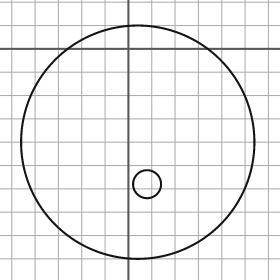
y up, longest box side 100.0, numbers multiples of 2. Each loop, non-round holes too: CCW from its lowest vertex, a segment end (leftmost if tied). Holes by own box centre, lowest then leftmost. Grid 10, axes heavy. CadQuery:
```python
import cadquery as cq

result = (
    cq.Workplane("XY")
    .moveTo(4.0, -40.0)
    .circle(50.0)
    .moveTo(8.0, -58.0)
    .circle(6.0)
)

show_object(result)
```